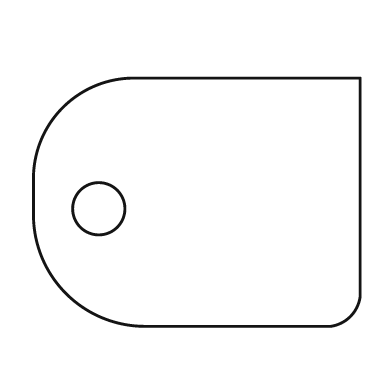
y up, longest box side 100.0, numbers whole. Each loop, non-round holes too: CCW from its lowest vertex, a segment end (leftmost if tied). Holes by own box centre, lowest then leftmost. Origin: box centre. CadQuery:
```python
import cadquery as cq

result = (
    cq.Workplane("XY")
    .moveTo(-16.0, -38.0)
    .lineTo(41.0, -38.0)
    .threePointArc((47.0, -35.0), (50.0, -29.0))
    .lineTo(50.0, 38.0)
    .lineTo(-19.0, 38.0)
    .threePointArc((-41.0, 29.0), (-50.0, 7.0))
    .lineTo(-50.0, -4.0)
    .threePointArc((-40.0, -28.0), (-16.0, -38.0))
    .close()
    .moveTo(-30.0, -2.0)
    .circle(8.0)
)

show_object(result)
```